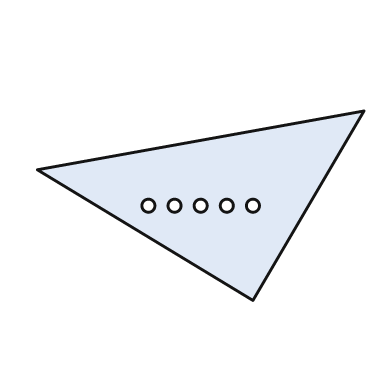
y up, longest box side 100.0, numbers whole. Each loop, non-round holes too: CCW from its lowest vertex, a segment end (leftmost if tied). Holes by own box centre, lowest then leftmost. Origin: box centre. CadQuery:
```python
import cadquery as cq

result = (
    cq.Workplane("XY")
    .moveTo(16.0, -29.0)
    .lineTo(50.0, 29.0)
    .lineTo(-50.0, 11.0)
    .close()
    .moveTo(-16.0, 0.0)
    .circle(2.0)
    .moveTo(-8.0, 0.0)
    .circle(2.0)
    .moveTo(0.0, 0.0)
    .circle(2.0)
    .moveTo(8.0, 0.0)
    .circle(2.0)
    .moveTo(16.0, 0.0)
    .circle(2.0)
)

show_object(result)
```